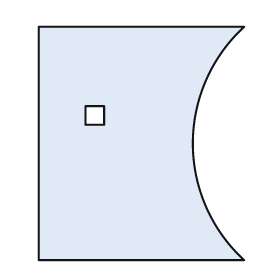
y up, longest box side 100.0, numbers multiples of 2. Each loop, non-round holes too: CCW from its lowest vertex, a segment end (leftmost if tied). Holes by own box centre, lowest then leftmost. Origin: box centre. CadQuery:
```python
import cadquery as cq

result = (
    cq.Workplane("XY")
    .moveTo(-44.0, -50.0)
    .lineTo(44.0, -50.0)
    .threePointArc((22.0, 0.0), (44.0, 50.0))
    .lineTo(-44.0, 50.0)
    .close()
    .moveTo(-24.0, 8.0)
    .lineTo(-16.0, 8.0)
    .lineTo(-16.0, 16.0)
    .lineTo(-24.0, 16.0)
    .close()
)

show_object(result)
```